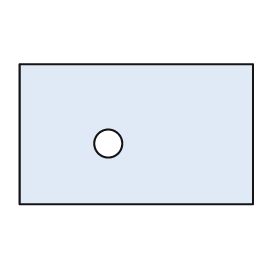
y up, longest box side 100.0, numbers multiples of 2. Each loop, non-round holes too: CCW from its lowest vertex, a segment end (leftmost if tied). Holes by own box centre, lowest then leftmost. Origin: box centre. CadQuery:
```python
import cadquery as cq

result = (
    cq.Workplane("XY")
    .moveTo(-50.0, -30.0)
    .lineTo(50.0, -30.0)
    .lineTo(50.0, 30.0)
    .lineTo(-50.0, 30.0)
    .close()
    .moveTo(-12.0, -4.0)
    .circle(6.0)
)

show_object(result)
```